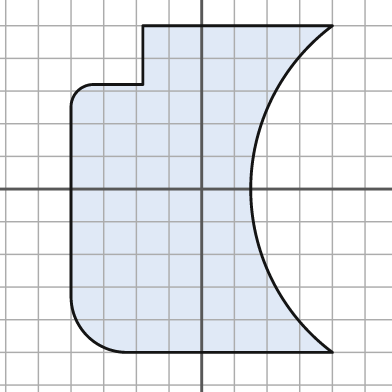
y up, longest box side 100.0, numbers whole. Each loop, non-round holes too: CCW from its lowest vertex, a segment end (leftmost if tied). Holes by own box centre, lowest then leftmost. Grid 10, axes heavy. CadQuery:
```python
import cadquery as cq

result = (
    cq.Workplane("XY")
    .moveTo(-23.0, -50.0)
    .lineTo(40.0, -50.0)
    .threePointArc((15.0, 0.0), (40.0, 50.0))
    .lineTo(-18.0, 50.0)
    .lineTo(-18.0, 32.0)
    .lineTo(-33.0, 32.0)
    .threePointArc((-38.0, 30.0), (-40.0, 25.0))
    .lineTo(-40.0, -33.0)
    .threePointArc((-35.0, -45.0), (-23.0, -50.0))
    .close()
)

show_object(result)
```